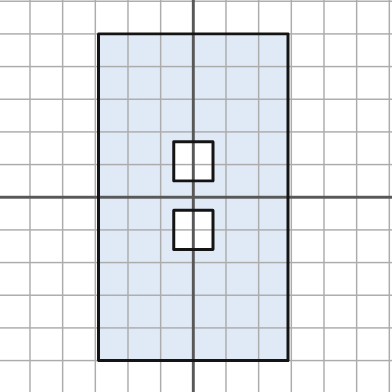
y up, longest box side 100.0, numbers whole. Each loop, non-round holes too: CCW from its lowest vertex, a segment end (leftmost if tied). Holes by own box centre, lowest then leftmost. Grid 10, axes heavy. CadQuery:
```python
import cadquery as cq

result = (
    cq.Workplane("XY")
    .moveTo(-29.0, -50.0)
    .lineTo(29.0, -50.0)
    .lineTo(29.0, 50.0)
    .lineTo(-29.0, 50.0)
    .close()
    .moveTo(-6.0, -16.0)
    .lineTo(6.0, -16.0)
    .lineTo(6.0, -4.0)
    .lineTo(-6.0, -4.0)
    .close()
    .moveTo(-6.0, 5.0)
    .lineTo(6.0, 5.0)
    .lineTo(6.0, 17.0)
    .lineTo(-6.0, 17.0)
    .close()
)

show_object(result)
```